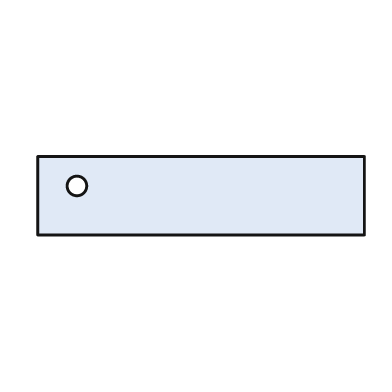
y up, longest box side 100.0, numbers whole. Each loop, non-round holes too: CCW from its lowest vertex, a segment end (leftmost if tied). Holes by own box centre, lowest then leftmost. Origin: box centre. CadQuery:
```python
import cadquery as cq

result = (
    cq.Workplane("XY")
    .moveTo(-50.0, -12.0)
    .lineTo(50.0, -12.0)
    .lineTo(50.0, 12.0)
    .lineTo(-50.0, 12.0)
    .close()
    .moveTo(-38.0, 3.0)
    .circle(3.0)
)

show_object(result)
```